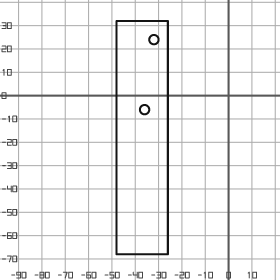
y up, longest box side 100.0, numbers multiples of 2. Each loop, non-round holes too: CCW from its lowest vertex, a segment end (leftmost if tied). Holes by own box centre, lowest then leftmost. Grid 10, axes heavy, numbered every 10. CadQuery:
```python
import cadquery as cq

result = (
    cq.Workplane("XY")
    .moveTo(-48.0, -68.0)
    .lineTo(-26.0, -68.0)
    .lineTo(-26.0, 32.0)
    .lineTo(-48.0, 32.0)
    .close()
    .moveTo(-36.0, -6.0)
    .circle(2.0)
    .moveTo(-32.0, 24.0)
    .circle(2.0)
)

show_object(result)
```